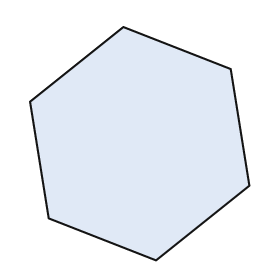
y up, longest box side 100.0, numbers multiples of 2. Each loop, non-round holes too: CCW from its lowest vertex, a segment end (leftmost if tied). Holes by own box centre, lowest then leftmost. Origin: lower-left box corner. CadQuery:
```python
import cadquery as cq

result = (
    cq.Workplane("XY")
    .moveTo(54.0, 0.0)
    .lineTo(94.0, 32.0)
    .lineTo(86.0, 82.0)
    .lineTo(40.0, 100.0)
    .lineTo(0.0, 68.0)
    .lineTo(8.0, 18.0)
    .close()
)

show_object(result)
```